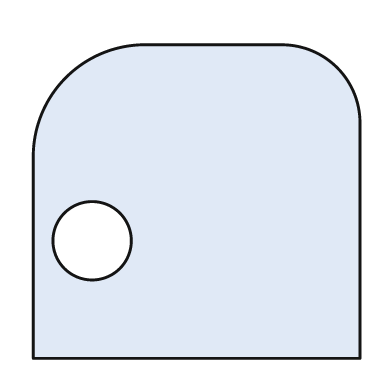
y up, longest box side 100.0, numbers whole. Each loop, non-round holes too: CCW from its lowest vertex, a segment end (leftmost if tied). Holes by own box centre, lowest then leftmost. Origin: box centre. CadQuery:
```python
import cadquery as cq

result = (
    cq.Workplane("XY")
    .moveTo(-50.0, -48.0)
    .lineTo(50.0, -48.0)
    .lineTo(50.0, 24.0)
    .threePointArc((43.0, 41.0), (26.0, 48.0))
    .lineTo(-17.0, 48.0)
    .threePointArc((-40.0, 38.0), (-50.0, 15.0))
    .close()
    .moveTo(-32.0, -12.0)
    .circle(12.0)
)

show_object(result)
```